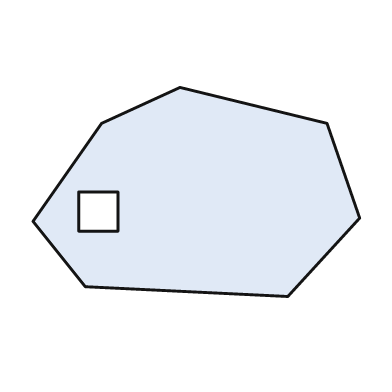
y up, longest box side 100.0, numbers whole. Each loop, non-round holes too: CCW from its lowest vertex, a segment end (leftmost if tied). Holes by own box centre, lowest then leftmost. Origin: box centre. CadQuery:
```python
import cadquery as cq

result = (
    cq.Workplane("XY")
    .moveTo(28.0, -32.0)
    .lineTo(50.0, -8.0)
    .lineTo(40.0, 21.0)
    .lineTo(-5.0, 32.0)
    .lineTo(-29.0, 21.0)
    .lineTo(-50.0, -9.0)
    .lineTo(-34.0, -29.0)
    .close()
    .moveTo(-36.0, -12.0)
    .lineTo(-24.0, -12.0)
    .lineTo(-24.0, 0.0)
    .lineTo(-36.0, 0.0)
    .close()
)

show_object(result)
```